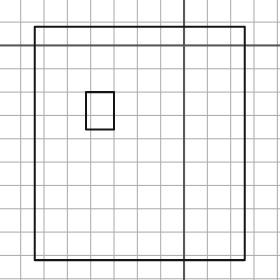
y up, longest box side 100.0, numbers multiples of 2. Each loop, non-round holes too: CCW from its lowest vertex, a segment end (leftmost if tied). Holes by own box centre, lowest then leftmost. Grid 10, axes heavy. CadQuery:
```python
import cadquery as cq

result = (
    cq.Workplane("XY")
    .moveTo(-64.0, -92.0)
    .lineTo(26.0, -92.0)
    .lineTo(26.0, 8.0)
    .lineTo(-64.0, 8.0)
    .close()
    .moveTo(-42.0, -36.0)
    .lineTo(-30.0, -36.0)
    .lineTo(-30.0, -20.0)
    .lineTo(-42.0, -20.0)
    .close()
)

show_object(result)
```